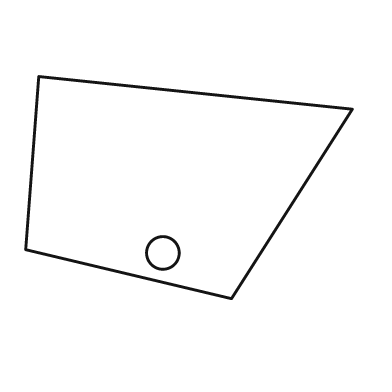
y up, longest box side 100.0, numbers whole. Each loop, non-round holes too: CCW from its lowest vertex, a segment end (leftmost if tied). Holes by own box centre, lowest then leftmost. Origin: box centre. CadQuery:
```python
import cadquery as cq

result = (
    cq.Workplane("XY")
    .moveTo(13.0, -34.0)
    .lineTo(50.0, 24.0)
    .lineTo(-46.0, 34.0)
    .lineTo(-50.0, -19.0)
    .close()
    .moveTo(-8.0, -20.0)
    .circle(5.0)
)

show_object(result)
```